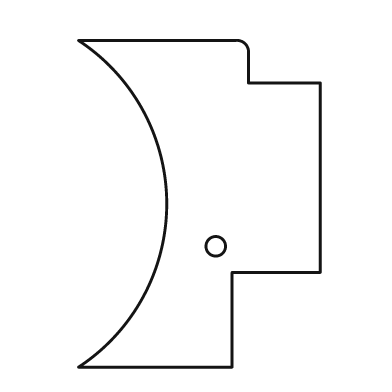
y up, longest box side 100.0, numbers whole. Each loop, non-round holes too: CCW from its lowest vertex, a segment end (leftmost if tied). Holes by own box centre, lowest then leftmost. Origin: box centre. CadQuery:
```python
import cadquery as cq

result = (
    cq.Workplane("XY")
    .moveTo(-37.0, -50.0)
    .lineTo(10.0, -50.0)
    .lineTo(10.0, -21.0)
    .lineTo(37.0, -21.0)
    .lineTo(37.0, 37.0)
    .lineTo(15.0, 37.0)
    .lineTo(15.0, 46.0)
    .threePointArc((14.0, 49.0), (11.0, 50.0))
    .lineTo(-37.0, 50.0)
    .threePointArc((-10.0, 0.0), (-37.0, -50.0))
    .close()
    .moveTo(5.0, -13.0)
    .circle(3.0)
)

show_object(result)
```